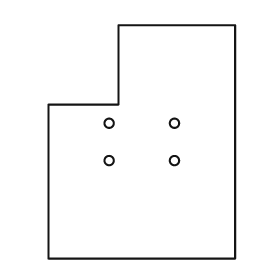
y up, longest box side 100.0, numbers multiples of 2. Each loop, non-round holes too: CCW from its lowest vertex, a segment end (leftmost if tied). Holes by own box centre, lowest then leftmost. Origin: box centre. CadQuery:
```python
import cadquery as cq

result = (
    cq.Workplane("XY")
    .moveTo(-40.0, -50.0)
    .lineTo(40.0, -50.0)
    .lineTo(40.0, 50.0)
    .lineTo(-10.0, 50.0)
    .lineTo(-10.0, 16.0)
    .lineTo(-40.0, 16.0)
    .close()
    .moveTo(-14.0, -8.0)
    .circle(2.0)
    .moveTo(14.0, -8.0)
    .circle(2.0)
    .moveTo(-14.0, 8.0)
    .circle(2.0)
    .moveTo(14.0, 8.0)
    .circle(2.0)
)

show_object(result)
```